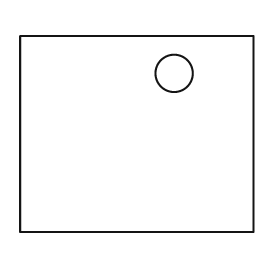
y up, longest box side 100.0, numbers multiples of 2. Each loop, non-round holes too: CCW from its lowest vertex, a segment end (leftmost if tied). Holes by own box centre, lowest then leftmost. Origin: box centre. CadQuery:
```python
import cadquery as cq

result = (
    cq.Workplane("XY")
    .moveTo(-50.0, -42.0)
    .lineTo(50.0, -42.0)
    .lineTo(50.0, 42.0)
    .lineTo(-50.0, 42.0)
    .close()
    .moveTo(16.0, 26.0)
    .circle(8.0)
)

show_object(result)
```